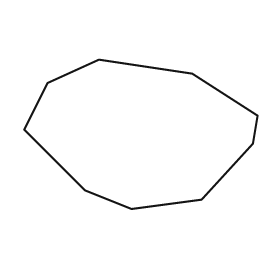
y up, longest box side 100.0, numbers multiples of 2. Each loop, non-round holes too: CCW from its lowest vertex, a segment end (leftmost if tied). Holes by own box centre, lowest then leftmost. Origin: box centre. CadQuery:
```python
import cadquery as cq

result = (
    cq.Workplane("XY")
    .moveTo(-4.0, -32.0)
    .lineTo(26.0, -28.0)
    .lineTo(48.0, -4.0)
    .lineTo(50.0, 8.0)
    .lineTo(22.0, 26.0)
    .lineTo(-18.0, 32.0)
    .lineTo(-40.0, 22.0)
    .lineTo(-50.0, 2.0)
    .lineTo(-24.0, -24.0)
    .close()
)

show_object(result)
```